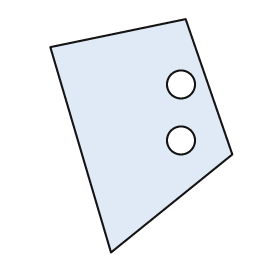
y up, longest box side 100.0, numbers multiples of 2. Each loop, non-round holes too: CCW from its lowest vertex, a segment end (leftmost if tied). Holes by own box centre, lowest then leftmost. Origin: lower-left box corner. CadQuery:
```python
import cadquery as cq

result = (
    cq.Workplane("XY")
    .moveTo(26.0, 0.0)
    .lineTo(78.0, 42.0)
    .lineTo(58.0, 100.0)
    .lineTo(0.0, 88.0)
    .close()
    .moveTo(56.0, 48.0)
    .circle(6.0)
    .moveTo(56.0, 72.0)
    .circle(6.0)
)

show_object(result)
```